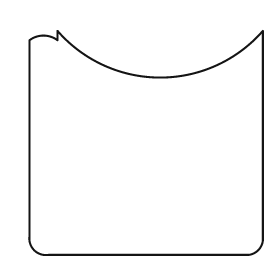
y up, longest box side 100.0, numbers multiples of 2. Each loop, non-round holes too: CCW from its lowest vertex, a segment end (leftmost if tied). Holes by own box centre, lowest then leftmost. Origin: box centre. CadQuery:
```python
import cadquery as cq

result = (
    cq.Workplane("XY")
    .moveTo(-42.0, -48.0)
    .lineTo(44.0, -48.0)
    .threePointArc((48.0, -46.0), (50.0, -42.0))
    .lineTo(50.0, 48.0)
    .threePointArc((6.0, 28.0), (-38.0, 48.0))
    .lineTo(-38.0, 44.0)
    .threePointArc((-44.0, 46.0), (-50.0, 44.0))
    .lineTo(-50.0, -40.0)
    .threePointArc((-48.0, -46.0), (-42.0, -48.0))
    .close()
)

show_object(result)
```